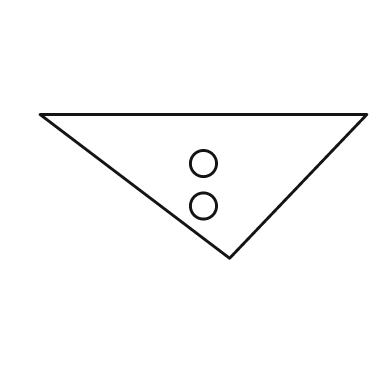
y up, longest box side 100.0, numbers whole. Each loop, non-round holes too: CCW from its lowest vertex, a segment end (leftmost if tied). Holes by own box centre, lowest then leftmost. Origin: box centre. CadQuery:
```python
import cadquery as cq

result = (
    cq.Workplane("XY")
    .moveTo(8.0, -22.0)
    .lineTo(50.0, 22.0)
    .lineTo(-50.0, 22.0)
    .close()
    .moveTo(0.0, -6.0)
    .circle(4.0)
    .moveTo(0.0, 7.0)
    .circle(4.0)
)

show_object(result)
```